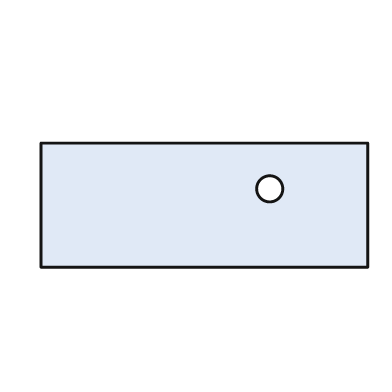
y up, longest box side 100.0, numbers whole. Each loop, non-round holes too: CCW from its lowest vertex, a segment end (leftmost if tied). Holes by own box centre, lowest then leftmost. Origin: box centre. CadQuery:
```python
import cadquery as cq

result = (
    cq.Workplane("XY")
    .moveTo(-50.0, -19.0)
    .lineTo(50.0, -19.0)
    .lineTo(50.0, 19.0)
    .lineTo(-50.0, 19.0)
    .close()
    .moveTo(20.0, 5.0)
    .circle(4.0)
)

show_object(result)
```